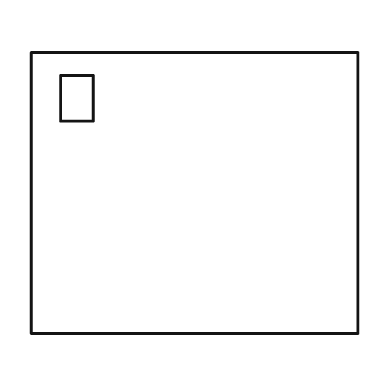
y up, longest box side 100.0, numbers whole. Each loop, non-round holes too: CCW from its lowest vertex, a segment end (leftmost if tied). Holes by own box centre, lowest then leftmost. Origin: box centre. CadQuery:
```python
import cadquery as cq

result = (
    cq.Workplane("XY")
    .moveTo(-50.0, -43.0)
    .lineTo(50.0, -43.0)
    .lineTo(50.0, 43.0)
    .lineTo(-50.0, 43.0)
    .close()
    .moveTo(-41.0, 22.0)
    .lineTo(-31.0, 22.0)
    .lineTo(-31.0, 36.0)
    .lineTo(-41.0, 36.0)
    .close()
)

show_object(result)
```